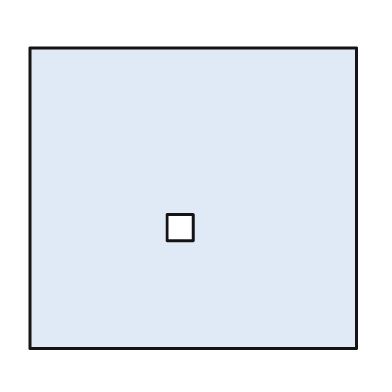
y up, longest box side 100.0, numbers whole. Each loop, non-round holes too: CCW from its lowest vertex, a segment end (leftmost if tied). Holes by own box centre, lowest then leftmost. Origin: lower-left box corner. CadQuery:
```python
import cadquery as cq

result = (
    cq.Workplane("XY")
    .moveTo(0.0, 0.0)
    .lineTo(100.0, 0.0)
    .lineTo(100.0, 92.0)
    .lineTo(0.0, 92.0)
    .close()
    .moveTo(42.0, 33.0)
    .lineTo(50.0, 33.0)
    .lineTo(50.0, 41.0)
    .lineTo(42.0, 41.0)
    .close()
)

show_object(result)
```